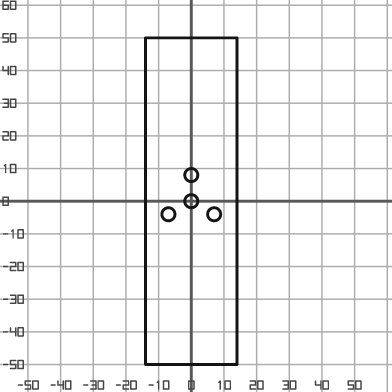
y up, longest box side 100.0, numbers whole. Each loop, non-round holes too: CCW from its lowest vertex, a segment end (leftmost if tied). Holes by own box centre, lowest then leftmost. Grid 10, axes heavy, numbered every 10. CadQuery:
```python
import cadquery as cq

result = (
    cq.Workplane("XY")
    .moveTo(-14.0, -50.0)
    .lineTo(14.0, -50.0)
    .lineTo(14.0, 50.0)
    .lineTo(-14.0, 50.0)
    .close()
    .moveTo(-7.0, -4.0)
    .circle(2.0)
    .moveTo(7.0, -4.0)
    .circle(2.0)
    .moveTo(0.0, 0.0)
    .circle(2.0)
    .moveTo(0.0, 8.0)
    .circle(2.0)
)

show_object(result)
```